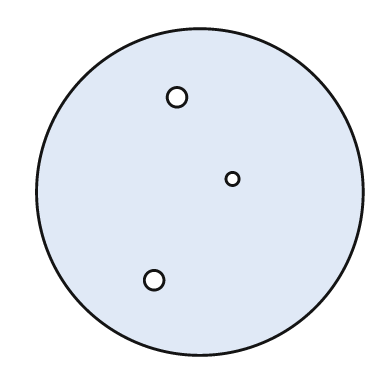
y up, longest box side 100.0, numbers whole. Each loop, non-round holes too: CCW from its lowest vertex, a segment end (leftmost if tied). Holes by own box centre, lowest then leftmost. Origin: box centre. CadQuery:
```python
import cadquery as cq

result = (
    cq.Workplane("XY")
    .moveTo(0.0, 0.0)
    .circle(50.0)
    .moveTo(-14.0, -27.0)
    .circle(3.0)
    .moveTo(10.0, 4.0)
    .circle(2.0)
    .moveTo(-7.0, 29.0)
    .circle(3.0)
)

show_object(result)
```